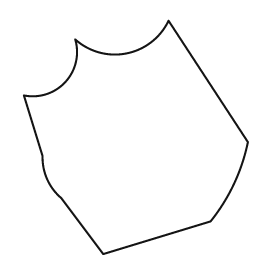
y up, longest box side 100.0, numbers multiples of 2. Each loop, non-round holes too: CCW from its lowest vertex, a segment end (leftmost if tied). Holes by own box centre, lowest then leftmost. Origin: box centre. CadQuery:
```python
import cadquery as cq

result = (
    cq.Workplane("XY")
    .moveTo(-14.0, -50.0)
    .lineTo(32.0, -36.0)
    .threePointArc((42.0, -20.0), (48.0, -2.0))
    .lineTo(14.0, 50.0)
    .threePointArc((-4.0, 36.0), (-26.0, 42.0))
    .threePointArc((-30.0, 24.0), (-48.0, 18.0))
    .lineTo(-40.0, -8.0)
    .threePointArc((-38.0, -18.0), (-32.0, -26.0))
    .close()
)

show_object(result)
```